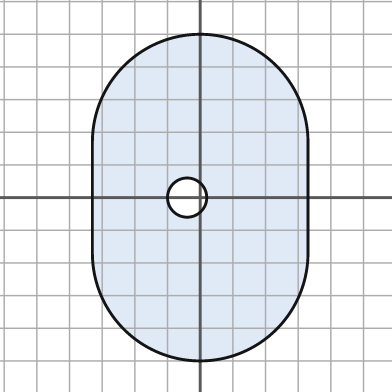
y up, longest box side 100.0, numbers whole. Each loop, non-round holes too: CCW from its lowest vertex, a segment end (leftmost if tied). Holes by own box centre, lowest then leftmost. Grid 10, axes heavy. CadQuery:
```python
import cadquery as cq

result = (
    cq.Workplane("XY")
    .moveTo(-33.0, -17.0)
    .threePointArc((0.0, -50.0), (33.0, -17.0))
    .lineTo(33.0, 17.0)
    .threePointArc((0.0, 50.0), (-33.0, 17.0))
    .close()
    .moveTo(-4.0, 0.0)
    .circle(6.0)
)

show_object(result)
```